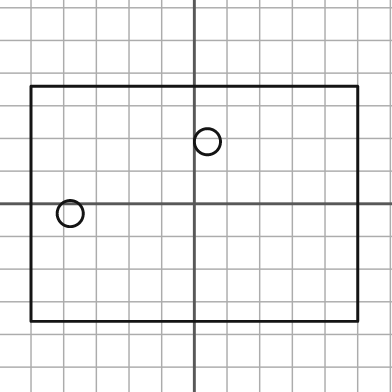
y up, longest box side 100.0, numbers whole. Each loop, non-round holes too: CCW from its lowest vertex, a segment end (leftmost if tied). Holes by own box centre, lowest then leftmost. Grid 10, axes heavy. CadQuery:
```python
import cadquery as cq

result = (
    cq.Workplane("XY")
    .moveTo(-50.0, -36.0)
    .lineTo(50.0, -36.0)
    .lineTo(50.0, 36.0)
    .lineTo(-50.0, 36.0)
    .close()
    .moveTo(-38.0, -3.0)
    .circle(4.0)
    .moveTo(4.0, 19.0)
    .circle(4.0)
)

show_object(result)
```